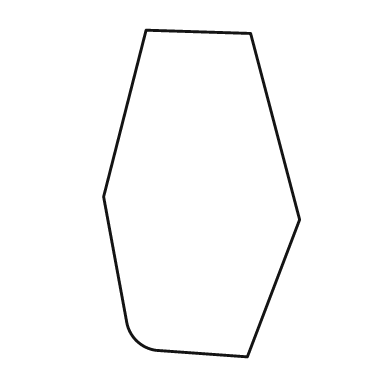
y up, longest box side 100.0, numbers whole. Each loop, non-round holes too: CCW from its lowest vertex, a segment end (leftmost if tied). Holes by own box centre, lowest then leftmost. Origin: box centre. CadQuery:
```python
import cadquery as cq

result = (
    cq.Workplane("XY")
    .moveTo(14.0, -50.0)
    .lineTo(30.0, -8.0)
    .lineTo(15.0, 49.0)
    .lineTo(-17.0, 50.0)
    .lineTo(-30.0, -1.0)
    .lineTo(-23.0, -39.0)
    .threePointArc((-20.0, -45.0), (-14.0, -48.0))
    .close()
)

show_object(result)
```